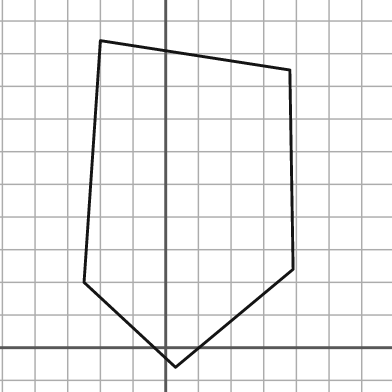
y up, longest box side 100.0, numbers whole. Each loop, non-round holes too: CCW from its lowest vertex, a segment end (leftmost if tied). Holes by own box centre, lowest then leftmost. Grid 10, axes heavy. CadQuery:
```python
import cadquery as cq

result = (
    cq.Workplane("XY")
    .moveTo(3.0, -6.0)
    .lineTo(39.0, 24.0)
    .lineTo(38.0, 85.0)
    .lineTo(-20.0, 94.0)
    .lineTo(-25.0, 20.0)
    .close()
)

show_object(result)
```